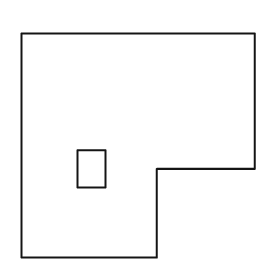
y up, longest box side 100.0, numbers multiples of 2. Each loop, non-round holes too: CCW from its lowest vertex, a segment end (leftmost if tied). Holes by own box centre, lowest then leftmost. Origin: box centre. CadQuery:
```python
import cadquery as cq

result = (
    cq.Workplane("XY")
    .moveTo(-50.0, -48.0)
    .lineTo(8.0, -48.0)
    .lineTo(8.0, -10.0)
    .lineTo(50.0, -10.0)
    .lineTo(50.0, 48.0)
    .lineTo(-50.0, 48.0)
    .close()
    .moveTo(-26.0, -18.0)
    .lineTo(-14.0, -18.0)
    .lineTo(-14.0, -2.0)
    .lineTo(-26.0, -2.0)
    .close()
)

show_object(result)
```